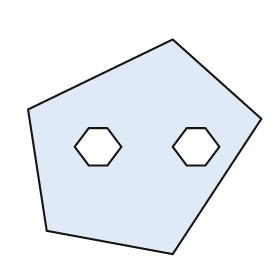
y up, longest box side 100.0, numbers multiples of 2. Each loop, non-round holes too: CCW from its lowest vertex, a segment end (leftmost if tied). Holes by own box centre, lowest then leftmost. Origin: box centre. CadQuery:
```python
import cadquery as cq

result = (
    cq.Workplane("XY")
    .moveTo(12.0, -46.0)
    .lineTo(50.0, 12.0)
    .lineTo(12.0, 46.0)
    .lineTo(-50.0, 16.0)
    .lineTo(-42.0, -36.0)
    .close()
    .moveTo(-24.0, -8.0)
    .lineTo(-16.0, -8.0)
    .lineTo(-10.0, 0.0)
    .lineTo(-16.0, 8.0)
    .lineTo(-24.0, 8.0)
    .lineTo(-30.0, 0.0)
    .close()
    .moveTo(18.0, -8.0)
    .lineTo(26.0, -8.0)
    .lineTo(32.0, 0.0)
    .lineTo(26.0, 8.0)
    .lineTo(18.0, 8.0)
    .lineTo(12.0, 0.0)
    .close()
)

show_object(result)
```